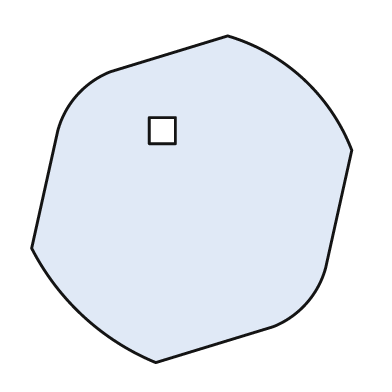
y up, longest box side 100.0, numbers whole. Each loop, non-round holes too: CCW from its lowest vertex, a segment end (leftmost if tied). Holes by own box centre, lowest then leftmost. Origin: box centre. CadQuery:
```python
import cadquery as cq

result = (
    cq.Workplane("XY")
    .moveTo(-11.0, -50.0)
    .lineTo(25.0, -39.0)
    .threePointArc((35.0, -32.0), (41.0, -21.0))
    .lineTo(49.0, 15.0)
    .threePointArc((34.0, 37.0), (11.0, 50.0))
    .lineTo(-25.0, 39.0)
    .threePointArc((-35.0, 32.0), (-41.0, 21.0))
    .lineTo(-49.0, -15.0)
    .threePointArc((-33.0, -36.0), (-11.0, -50.0))
    .close()
    .moveTo(-13.0, 17.0)
    .lineTo(-5.0, 17.0)
    .lineTo(-5.0, 25.0)
    .lineTo(-13.0, 25.0)
    .close()
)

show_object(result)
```